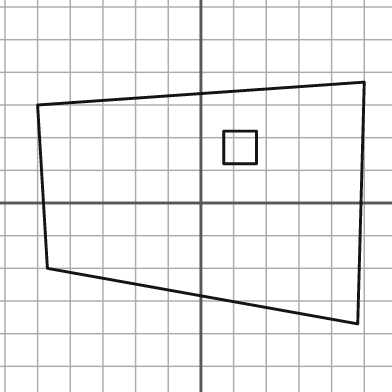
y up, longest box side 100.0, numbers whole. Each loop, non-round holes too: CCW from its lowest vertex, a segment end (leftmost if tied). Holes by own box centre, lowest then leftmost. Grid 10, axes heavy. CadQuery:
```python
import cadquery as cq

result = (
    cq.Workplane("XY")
    .moveTo(48.0, -37.0)
    .lineTo(50.0, 37.0)
    .lineTo(-50.0, 30.0)
    .lineTo(-47.0, -20.0)
    .close()
    .moveTo(7.0, 12.0)
    .lineTo(17.0, 12.0)
    .lineTo(17.0, 22.0)
    .lineTo(7.0, 22.0)
    .close()
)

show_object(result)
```